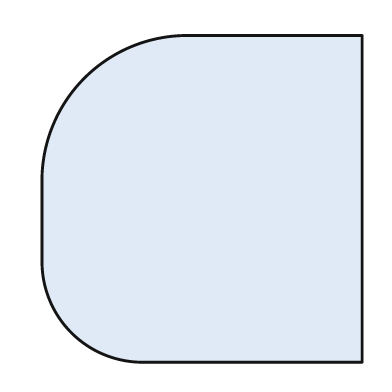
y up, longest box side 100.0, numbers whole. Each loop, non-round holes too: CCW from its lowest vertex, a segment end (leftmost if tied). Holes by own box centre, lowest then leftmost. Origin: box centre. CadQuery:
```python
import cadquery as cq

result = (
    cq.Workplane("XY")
    .moveTo(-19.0, -50.0)
    .lineTo(49.0, -50.0)
    .lineTo(49.0, 50.0)
    .lineTo(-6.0, 50.0)
    .threePointArc((-36.0, 37.0), (-49.0, 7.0))
    .lineTo(-49.0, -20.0)
    .threePointArc((-40.0, -41.0), (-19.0, -50.0))
    .close()
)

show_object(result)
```